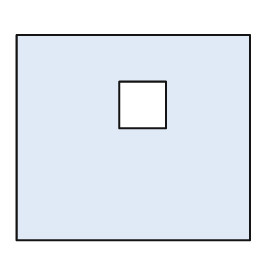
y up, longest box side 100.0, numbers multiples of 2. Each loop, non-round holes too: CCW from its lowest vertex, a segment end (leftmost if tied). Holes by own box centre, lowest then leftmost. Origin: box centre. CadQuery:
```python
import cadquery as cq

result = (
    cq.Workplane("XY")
    .moveTo(-50.0, -44.0)
    .lineTo(50.0, -44.0)
    .lineTo(50.0, 44.0)
    .lineTo(-50.0, 44.0)
    .close()
    .moveTo(-6.0, 4.0)
    .lineTo(14.0, 4.0)
    .lineTo(14.0, 24.0)
    .lineTo(-6.0, 24.0)
    .close()
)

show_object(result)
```